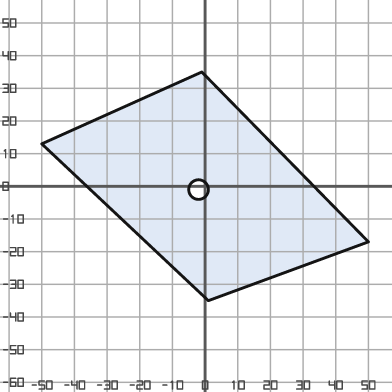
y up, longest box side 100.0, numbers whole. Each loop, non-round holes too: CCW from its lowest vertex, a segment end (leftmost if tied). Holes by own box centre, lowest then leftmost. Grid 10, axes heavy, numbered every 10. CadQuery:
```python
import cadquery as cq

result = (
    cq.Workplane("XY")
    .moveTo(1.0, -35.0)
    .lineTo(50.0, -17.0)
    .lineTo(-1.0, 35.0)
    .lineTo(-50.0, 13.0)
    .close()
    .moveTo(-2.0, -1.0)
    .circle(3.0)
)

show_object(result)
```